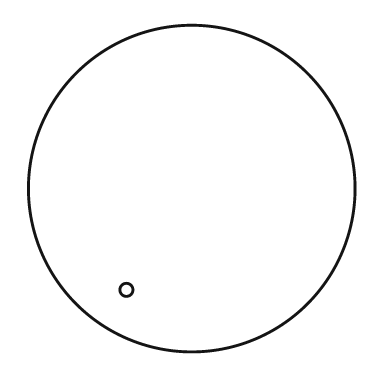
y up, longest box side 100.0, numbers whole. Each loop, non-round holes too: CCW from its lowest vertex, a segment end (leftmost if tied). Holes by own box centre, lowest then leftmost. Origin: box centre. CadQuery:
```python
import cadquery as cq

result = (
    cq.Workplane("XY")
    .moveTo(0.0, 0.0)
    .circle(50.0)
    .moveTo(-20.0, -31.0)
    .circle(2.0)
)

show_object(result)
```